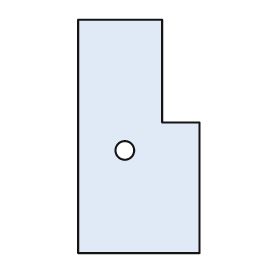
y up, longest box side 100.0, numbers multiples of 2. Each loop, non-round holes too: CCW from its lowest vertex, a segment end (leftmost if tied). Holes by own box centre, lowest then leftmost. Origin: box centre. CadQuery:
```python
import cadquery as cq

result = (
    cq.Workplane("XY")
    .moveTo(-26.0, -50.0)
    .lineTo(26.0, -50.0)
    .lineTo(26.0, 6.0)
    .lineTo(10.0, 6.0)
    .lineTo(10.0, 50.0)
    .lineTo(-26.0, 50.0)
    .close()
    .moveTo(-6.0, -6.0)
    .circle(4.0)
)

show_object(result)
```